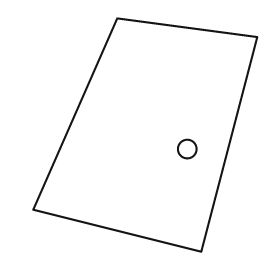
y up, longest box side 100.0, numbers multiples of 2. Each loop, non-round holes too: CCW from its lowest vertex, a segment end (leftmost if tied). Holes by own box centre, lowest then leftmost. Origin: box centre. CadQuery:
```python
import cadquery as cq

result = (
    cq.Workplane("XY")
    .moveTo(24.0, -50.0)
    .lineTo(48.0, 42.0)
    .lineTo(-12.0, 50.0)
    .lineTo(-48.0, -32.0)
    .close()
    .moveTo(18.0, -6.0)
    .circle(4.0)
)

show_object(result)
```